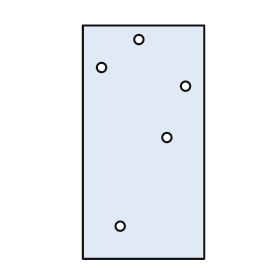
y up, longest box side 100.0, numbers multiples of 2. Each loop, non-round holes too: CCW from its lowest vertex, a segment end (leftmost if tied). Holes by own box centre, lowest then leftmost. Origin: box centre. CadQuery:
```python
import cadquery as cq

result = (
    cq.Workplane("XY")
    .moveTo(-26.0, -50.0)
    .lineTo(26.0, -50.0)
    .lineTo(26.0, 50.0)
    .lineTo(-26.0, 50.0)
    .close()
    .moveTo(-10.0, -36.0)
    .circle(2.0)
    .moveTo(10.0, 2.0)
    .circle(2.0)
    .moveTo(18.0, 24.0)
    .circle(2.0)
    .moveTo(-18.0, 32.0)
    .circle(2.0)
    .moveTo(-2.0, 44.0)
    .circle(2.0)
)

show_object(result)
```